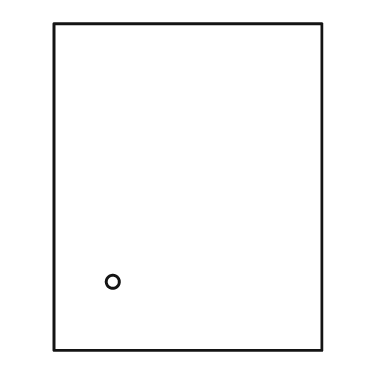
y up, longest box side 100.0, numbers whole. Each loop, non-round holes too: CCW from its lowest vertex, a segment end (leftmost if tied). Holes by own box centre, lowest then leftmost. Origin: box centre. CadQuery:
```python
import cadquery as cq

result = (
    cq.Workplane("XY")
    .moveTo(-41.0, -50.0)
    .lineTo(41.0, -50.0)
    .lineTo(41.0, 50.0)
    .lineTo(-41.0, 50.0)
    .close()
    .moveTo(-23.0, -29.0)
    .circle(2.0)
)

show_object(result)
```